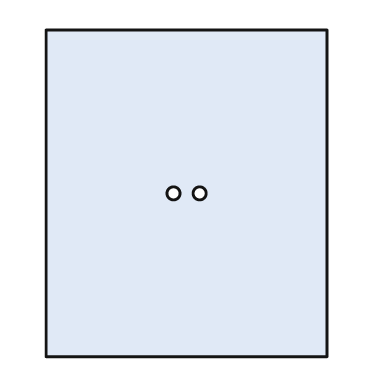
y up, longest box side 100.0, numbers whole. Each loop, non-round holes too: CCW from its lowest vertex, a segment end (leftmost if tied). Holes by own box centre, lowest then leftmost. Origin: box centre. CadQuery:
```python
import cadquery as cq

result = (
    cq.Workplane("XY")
    .moveTo(-43.0, -50.0)
    .lineTo(43.0, -50.0)
    .lineTo(43.0, 50.0)
    .lineTo(-43.0, 50.0)
    .close()
    .moveTo(-4.0, 0.0)
    .circle(2.0)
    .moveTo(4.0, 0.0)
    .circle(2.0)
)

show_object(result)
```